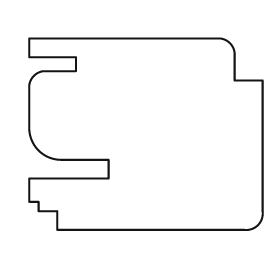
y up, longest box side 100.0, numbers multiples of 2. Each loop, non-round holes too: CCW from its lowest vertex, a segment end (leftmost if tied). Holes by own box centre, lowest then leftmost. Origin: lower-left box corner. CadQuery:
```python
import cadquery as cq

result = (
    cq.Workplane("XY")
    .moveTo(12.0, 0.0)
    .lineTo(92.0, 0.0)
    .threePointArc((98.0, 2.0), (100.0, 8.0))
    .lineTo(100.0, 64.0)
    .lineTo(88.0, 64.0)
    .lineTo(88.0, 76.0)
    .threePointArc((86.0, 80.0), (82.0, 82.0))
    .lineTo(0.0, 82.0)
    .lineTo(0.0, 74.0)
    .lineTo(20.0, 74.0)
    .lineTo(20.0, 68.0)
    .lineTo(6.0, 68.0)
    .threePointArc((2.0, 66.0), (0.0, 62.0))
    .lineTo(0.0, 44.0)
    .threePointArc((4.0, 34.0), (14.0, 30.0))
    .lineTo(34.0, 30.0)
    .lineTo(34.0, 22.0)
    .lineTo(0.0, 22.0)
    .lineTo(0.0, 12.0)
    .lineTo(4.0, 12.0)
    .lineTo(4.0, 8.0)
    .lineTo(12.0, 8.0)
    .close()
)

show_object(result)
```